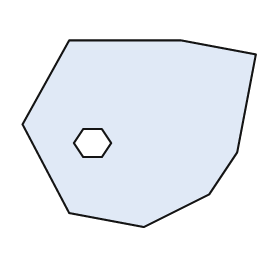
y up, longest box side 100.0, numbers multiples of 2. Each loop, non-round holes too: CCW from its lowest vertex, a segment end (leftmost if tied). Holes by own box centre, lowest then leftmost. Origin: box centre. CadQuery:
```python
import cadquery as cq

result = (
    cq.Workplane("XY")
    .moveTo(2.0, -40.0)
    .lineTo(30.0, -26.0)
    .lineTo(42.0, -8.0)
    .lineTo(50.0, 34.0)
    .lineTo(18.0, 40.0)
    .lineTo(-30.0, 40.0)
    .lineTo(-50.0, 4.0)
    .lineTo(-30.0, -34.0)
    .close()
    .moveTo(-24.0, -10.0)
    .lineTo(-16.0, -10.0)
    .lineTo(-12.0, -4.0)
    .lineTo(-16.0, 2.0)
    .lineTo(-24.0, 2.0)
    .lineTo(-28.0, -4.0)
    .close()
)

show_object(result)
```